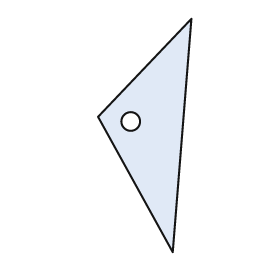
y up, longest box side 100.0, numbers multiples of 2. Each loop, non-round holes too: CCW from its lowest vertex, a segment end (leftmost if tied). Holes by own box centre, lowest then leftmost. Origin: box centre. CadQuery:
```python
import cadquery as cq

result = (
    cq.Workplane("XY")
    .moveTo(12.0, -50.0)
    .lineTo(20.0, 50.0)
    .lineTo(-20.0, 8.0)
    .close()
    .moveTo(-6.0, 6.0)
    .circle(4.0)
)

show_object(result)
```